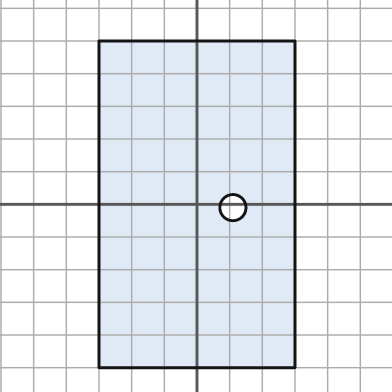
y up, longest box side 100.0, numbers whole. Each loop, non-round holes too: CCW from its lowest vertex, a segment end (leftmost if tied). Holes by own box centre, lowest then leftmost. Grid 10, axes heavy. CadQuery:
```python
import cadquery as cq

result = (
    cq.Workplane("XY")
    .moveTo(-30.0, -50.0)
    .lineTo(30.0, -50.0)
    .lineTo(30.0, 50.0)
    .lineTo(-30.0, 50.0)
    .close()
    .moveTo(11.0, -1.0)
    .circle(4.0)
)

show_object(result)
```